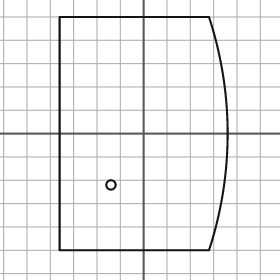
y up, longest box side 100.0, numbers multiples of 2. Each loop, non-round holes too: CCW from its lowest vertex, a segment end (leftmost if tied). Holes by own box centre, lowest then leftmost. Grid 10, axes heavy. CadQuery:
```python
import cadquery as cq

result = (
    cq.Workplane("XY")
    .moveTo(-36.0, -50.0)
    .lineTo(28.0, -50.0)
    .threePointArc((36.0, 0.0), (28.0, 50.0))
    .lineTo(-36.0, 50.0)
    .close()
    .moveTo(-14.0, -22.0)
    .circle(2.0)
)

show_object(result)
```